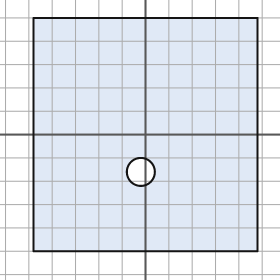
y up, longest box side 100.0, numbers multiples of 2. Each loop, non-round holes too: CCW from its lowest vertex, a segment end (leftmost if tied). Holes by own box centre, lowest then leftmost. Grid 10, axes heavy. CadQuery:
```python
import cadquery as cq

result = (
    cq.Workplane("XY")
    .moveTo(-48.0, -50.0)
    .lineTo(48.0, -50.0)
    .lineTo(48.0, 50.0)
    .lineTo(-48.0, 50.0)
    .close()
    .moveTo(-2.0, -16.0)
    .circle(6.0)
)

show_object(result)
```